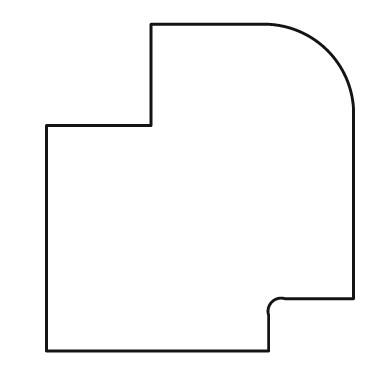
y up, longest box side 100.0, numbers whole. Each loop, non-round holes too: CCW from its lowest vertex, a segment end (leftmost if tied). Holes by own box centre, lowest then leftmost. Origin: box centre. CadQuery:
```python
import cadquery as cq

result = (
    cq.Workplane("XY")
    .moveTo(-47.0, -50.0)
    .lineTo(21.0, -50.0)
    .lineTo(21.0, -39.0)
    .threePointArc((22.0, -35.0), (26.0, -34.0))
    .lineTo(47.0, -34.0)
    .lineTo(47.0, 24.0)
    .threePointArc((39.0, 42.0), (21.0, 50.0))
    .lineTo(-15.0, 50.0)
    .lineTo(-15.0, 19.0)
    .lineTo(-47.0, 19.0)
    .close()
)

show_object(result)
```